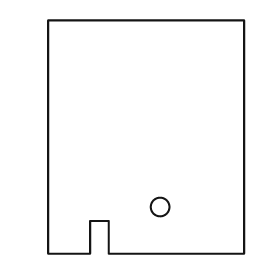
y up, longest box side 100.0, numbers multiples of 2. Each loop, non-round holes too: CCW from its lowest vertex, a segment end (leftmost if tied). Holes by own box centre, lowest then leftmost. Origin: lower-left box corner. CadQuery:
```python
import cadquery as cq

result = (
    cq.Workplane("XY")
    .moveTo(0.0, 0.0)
    .lineTo(18.0, 0.0)
    .lineTo(18.0, 14.0)
    .lineTo(26.0, 14.0)
    .lineTo(26.0, 0.0)
    .lineTo(84.0, 0.0)
    .lineTo(84.0, 100.0)
    .lineTo(0.0, 100.0)
    .close()
    .moveTo(48.0, 20.0)
    .circle(4.0)
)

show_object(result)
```